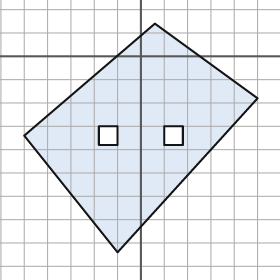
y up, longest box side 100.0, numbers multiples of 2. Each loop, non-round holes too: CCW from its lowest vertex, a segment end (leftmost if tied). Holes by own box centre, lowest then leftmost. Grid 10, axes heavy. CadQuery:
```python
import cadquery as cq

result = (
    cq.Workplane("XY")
    .moveTo(-10.0, -84.0)
    .lineTo(50.0, -18.0)
    .lineTo(6.0, 14.0)
    .lineTo(-50.0, -34.0)
    .close()
    .moveTo(-18.0, -38.0)
    .lineTo(-10.0, -38.0)
    .lineTo(-10.0, -30.0)
    .lineTo(-18.0, -30.0)
    .close()
    .moveTo(10.0, -38.0)
    .lineTo(18.0, -38.0)
    .lineTo(18.0, -30.0)
    .lineTo(10.0, -30.0)
    .close()
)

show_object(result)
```